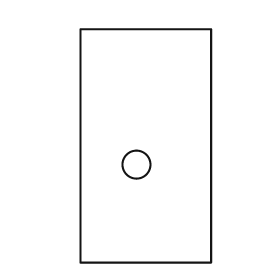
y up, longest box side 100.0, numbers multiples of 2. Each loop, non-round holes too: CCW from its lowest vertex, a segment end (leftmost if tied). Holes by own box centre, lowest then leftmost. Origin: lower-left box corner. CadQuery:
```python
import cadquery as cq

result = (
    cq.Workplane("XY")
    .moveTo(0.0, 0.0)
    .lineTo(56.0, 0.0)
    .lineTo(56.0, 100.0)
    .lineTo(0.0, 100.0)
    .close()
    .moveTo(24.0, 42.0)
    .circle(6.0)
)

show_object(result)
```